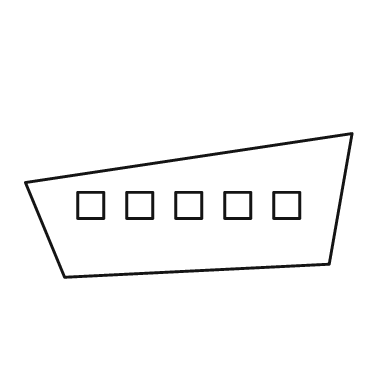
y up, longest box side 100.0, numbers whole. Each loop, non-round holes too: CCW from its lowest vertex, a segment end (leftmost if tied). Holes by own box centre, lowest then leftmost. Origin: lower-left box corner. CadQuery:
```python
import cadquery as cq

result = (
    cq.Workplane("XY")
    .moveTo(12.0, 0.0)
    .lineTo(93.0, 4.0)
    .lineTo(100.0, 44.0)
    .lineTo(0.0, 29.0)
    .close()
    .moveTo(16.0, 18.0)
    .lineTo(24.0, 18.0)
    .lineTo(24.0, 26.0)
    .lineTo(16.0, 26.0)
    .close()
    .moveTo(31.0, 18.0)
    .lineTo(39.0, 18.0)
    .lineTo(39.0, 26.0)
    .lineTo(31.0, 26.0)
    .close()
    .moveTo(46.0, 18.0)
    .lineTo(54.0, 18.0)
    .lineTo(54.0, 26.0)
    .lineTo(46.0, 26.0)
    .close()
    .moveTo(61.0, 18.0)
    .lineTo(69.0, 18.0)
    .lineTo(69.0, 26.0)
    .lineTo(61.0, 26.0)
    .close()
    .moveTo(76.0, 18.0)
    .lineTo(84.0, 18.0)
    .lineTo(84.0, 26.0)
    .lineTo(76.0, 26.0)
    .close()
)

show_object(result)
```